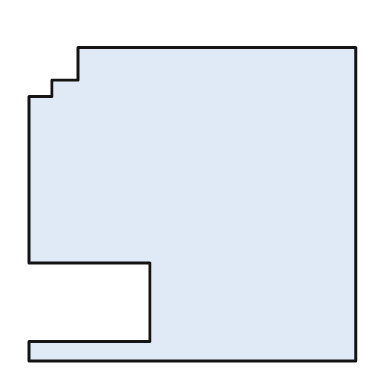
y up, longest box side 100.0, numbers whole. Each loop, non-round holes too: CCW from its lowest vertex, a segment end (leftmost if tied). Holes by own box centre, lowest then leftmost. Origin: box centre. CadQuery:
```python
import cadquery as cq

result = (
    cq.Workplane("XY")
    .moveTo(-50.0, -48.0)
    .lineTo(50.0, -48.0)
    .lineTo(50.0, 48.0)
    .lineTo(-35.0, 48.0)
    .lineTo(-35.0, 38.0)
    .lineTo(-43.0, 38.0)
    .lineTo(-43.0, 33.0)
    .lineTo(-50.0, 33.0)
    .lineTo(-50.0, -18.0)
    .lineTo(-13.0, -18.0)
    .lineTo(-13.0, -42.0)
    .lineTo(-50.0, -42.0)
    .close()
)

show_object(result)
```